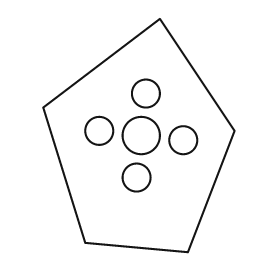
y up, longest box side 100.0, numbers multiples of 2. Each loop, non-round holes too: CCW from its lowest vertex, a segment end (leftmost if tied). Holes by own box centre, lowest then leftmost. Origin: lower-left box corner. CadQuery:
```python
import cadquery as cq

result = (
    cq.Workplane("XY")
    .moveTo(62.0, 0.0)
    .lineTo(82.0, 52.0)
    .lineTo(50.0, 100.0)
    .lineTo(0.0, 62.0)
    .lineTo(18.0, 4.0)
    .close()
    .moveTo(40.0, 32.0)
    .circle(6.0)
    .moveTo(60.0, 48.0)
    .circle(6.0)
    .moveTo(42.0, 50.0)
    .circle(8.0)
    .moveTo(24.0, 52.0)
    .circle(6.0)
    .moveTo(44.0, 68.0)
    .circle(6.0)
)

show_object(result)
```